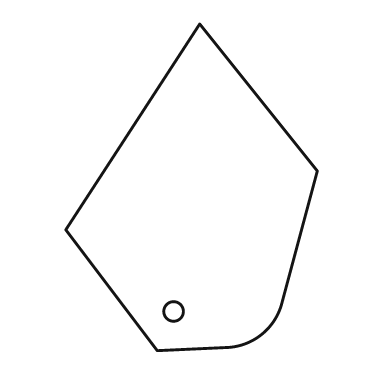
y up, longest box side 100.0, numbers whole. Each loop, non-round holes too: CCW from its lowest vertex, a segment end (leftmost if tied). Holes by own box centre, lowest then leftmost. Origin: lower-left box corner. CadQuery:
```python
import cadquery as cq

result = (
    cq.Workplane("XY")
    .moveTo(28.0, 0.0)
    .lineTo(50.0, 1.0)
    .threePointArc((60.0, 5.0), (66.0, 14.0))
    .lineTo(77.0, 55.0)
    .lineTo(41.0, 100.0)
    .lineTo(0.0, 37.0)
    .close()
    .moveTo(33.0, 12.0)
    .circle(3.0)
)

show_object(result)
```